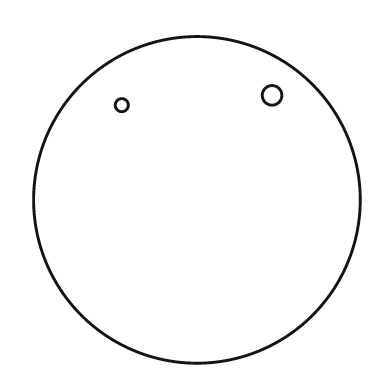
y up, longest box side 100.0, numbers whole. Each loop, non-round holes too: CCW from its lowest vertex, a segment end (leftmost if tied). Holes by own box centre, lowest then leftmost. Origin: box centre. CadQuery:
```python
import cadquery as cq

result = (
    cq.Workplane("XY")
    .moveTo(0.0, 0.0)
    .circle(50.0)
    .moveTo(-23.0, 29.0)
    .circle(2.0)
    .moveTo(23.0, 32.0)
    .circle(3.0)
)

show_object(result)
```